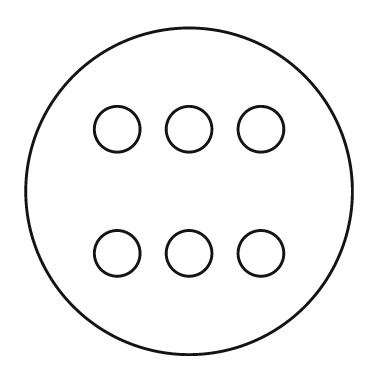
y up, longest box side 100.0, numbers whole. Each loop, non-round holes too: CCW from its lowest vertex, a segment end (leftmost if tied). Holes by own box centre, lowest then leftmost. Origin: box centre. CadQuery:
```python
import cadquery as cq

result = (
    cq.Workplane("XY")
    .moveTo(0.0, 0.0)
    .circle(50.0)
    .moveTo(-22.0, -19.0)
    .circle(7.0)
    .moveTo(0.0, -19.0)
    .circle(7.0)
    .moveTo(22.0, -19.0)
    .circle(7.0)
    .moveTo(-22.0, 19.0)
    .circle(7.0)
    .moveTo(0.0, 19.0)
    .circle(7.0)
    .moveTo(22.0, 19.0)
    .circle(7.0)
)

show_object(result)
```